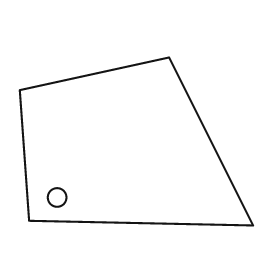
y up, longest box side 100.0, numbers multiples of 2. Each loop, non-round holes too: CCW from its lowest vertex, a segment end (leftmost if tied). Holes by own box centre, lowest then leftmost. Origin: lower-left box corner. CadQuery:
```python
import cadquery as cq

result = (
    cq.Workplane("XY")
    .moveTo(100.0, 0.0)
    .lineTo(64.0, 72.0)
    .lineTo(0.0, 58.0)
    .lineTo(4.0, 2.0)
    .close()
    .moveTo(16.0, 12.0)
    .circle(4.0)
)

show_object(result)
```